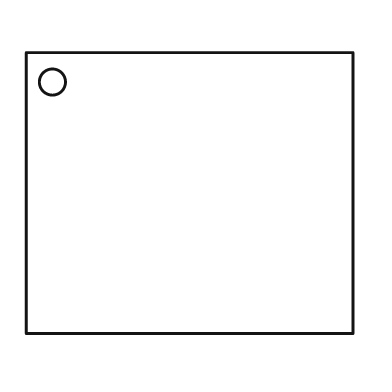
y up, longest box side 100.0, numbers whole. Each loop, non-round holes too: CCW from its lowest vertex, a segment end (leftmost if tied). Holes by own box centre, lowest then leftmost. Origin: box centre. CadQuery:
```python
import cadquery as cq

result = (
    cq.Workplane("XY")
    .moveTo(-50.0, -43.0)
    .lineTo(50.0, -43.0)
    .lineTo(50.0, 43.0)
    .lineTo(-50.0, 43.0)
    .close()
    .moveTo(-42.0, 34.0)
    .circle(4.0)
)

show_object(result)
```